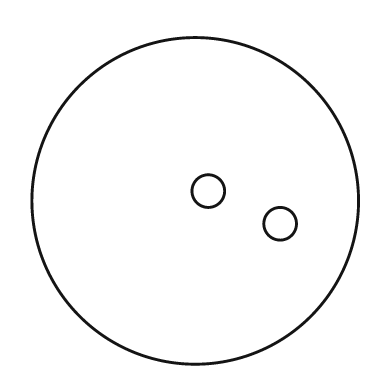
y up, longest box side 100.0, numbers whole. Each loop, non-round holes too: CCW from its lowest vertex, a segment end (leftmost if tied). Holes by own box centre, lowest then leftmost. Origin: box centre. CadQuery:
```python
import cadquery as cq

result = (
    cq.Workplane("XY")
    .moveTo(0.0, 0.0)
    .circle(50.0)
    .moveTo(26.0, -7.0)
    .circle(5.0)
    .moveTo(4.0, 3.0)
    .circle(5.0)
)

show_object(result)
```